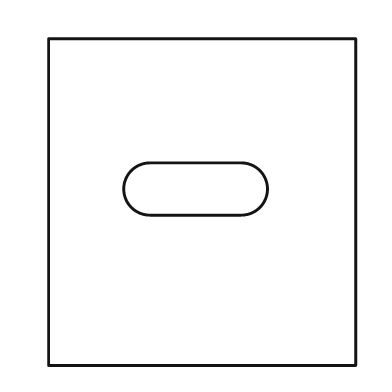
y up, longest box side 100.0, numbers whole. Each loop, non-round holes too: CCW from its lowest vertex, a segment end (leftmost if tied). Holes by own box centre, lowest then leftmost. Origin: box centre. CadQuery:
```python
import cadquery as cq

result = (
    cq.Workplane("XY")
    .moveTo(-47.0, -50.0)
    .lineTo(47.0, -50.0)
    .lineTo(47.0, 50.0)
    .lineTo(-47.0, 50.0)
    .close()
    .moveTo(-16.0, -4.0)
    .lineTo(12.0, -4.0)
    .threePointArc((20.0, 4.0), (12.0, 12.0))
    .lineTo(-16.0, 12.0)
    .threePointArc((-24.0, 4.0), (-16.0, -4.0))
    .close()
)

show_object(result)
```